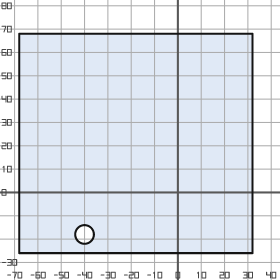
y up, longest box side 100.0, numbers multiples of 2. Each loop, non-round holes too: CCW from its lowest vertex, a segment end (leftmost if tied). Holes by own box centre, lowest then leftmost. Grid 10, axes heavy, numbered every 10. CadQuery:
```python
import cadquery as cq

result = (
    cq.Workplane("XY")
    .moveTo(-68.0, -26.0)
    .lineTo(32.0, -26.0)
    .lineTo(32.0, 68.0)
    .lineTo(-68.0, 68.0)
    .close()
    .moveTo(-40.0, -18.0)
    .circle(4.0)
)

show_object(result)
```